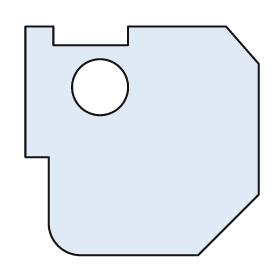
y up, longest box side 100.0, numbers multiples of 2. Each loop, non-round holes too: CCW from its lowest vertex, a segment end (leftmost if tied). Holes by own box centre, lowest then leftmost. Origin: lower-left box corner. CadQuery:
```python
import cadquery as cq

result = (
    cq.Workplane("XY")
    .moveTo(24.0, 0.0)
    .lineTo(74.0, 0.0)
    .lineTo(100.0, 26.0)
    .lineTo(100.0, 82.0)
    .lineTo(86.0, 98.0)
    .lineTo(44.0, 98.0)
    .lineTo(44.0, 90.0)
    .lineTo(12.0, 90.0)
    .lineTo(12.0, 98.0)
    .lineTo(0.0, 98.0)
    .lineTo(0.0, 42.0)
    .lineTo(10.0, 42.0)
    .lineTo(10.0, 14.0)
    .threePointArc((14.0, 4.0), (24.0, 0.0))
    .close()
    .moveTo(32.0, 72.0)
    .circle(12.0)
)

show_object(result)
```